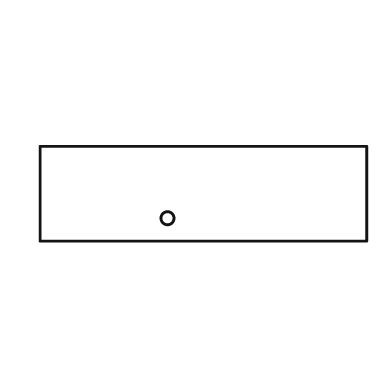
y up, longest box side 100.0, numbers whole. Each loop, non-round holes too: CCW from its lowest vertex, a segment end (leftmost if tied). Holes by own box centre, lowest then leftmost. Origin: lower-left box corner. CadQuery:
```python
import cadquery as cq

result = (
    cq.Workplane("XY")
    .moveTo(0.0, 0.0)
    .lineTo(100.0, 0.0)
    .lineTo(100.0, 29.0)
    .lineTo(0.0, 29.0)
    .close()
    .moveTo(39.0, 7.0)
    .circle(2.0)
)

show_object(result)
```